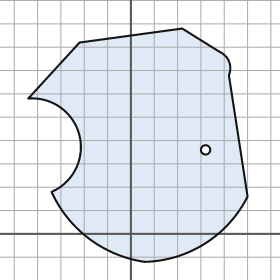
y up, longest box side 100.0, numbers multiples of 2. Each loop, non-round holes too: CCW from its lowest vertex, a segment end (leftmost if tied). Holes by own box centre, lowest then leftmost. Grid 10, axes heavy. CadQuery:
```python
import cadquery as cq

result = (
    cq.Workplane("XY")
    .moveTo(6.0, -12.0)
    .threePointArc((32.0, -4.0), (50.0, 16.0))
    .lineTo(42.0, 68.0)
    .threePointArc((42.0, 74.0), (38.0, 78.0))
    .lineTo(22.0, 88.0)
    .lineTo(-22.0, 82.0)
    .lineTo(-44.0, 58.0)
    .threePointArc((-22.0, 42.0), (-34.0, 18.0))
    .threePointArc((-18.0, -2.0), (6.0, -12.0))
    .close()
    .moveTo(32.0, 36.0)
    .circle(2.0)
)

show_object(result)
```